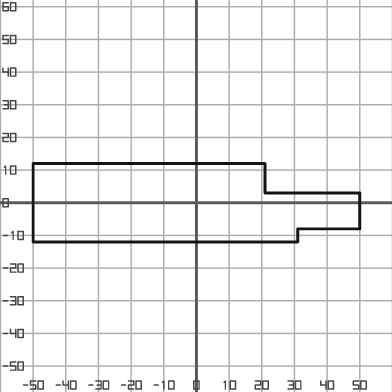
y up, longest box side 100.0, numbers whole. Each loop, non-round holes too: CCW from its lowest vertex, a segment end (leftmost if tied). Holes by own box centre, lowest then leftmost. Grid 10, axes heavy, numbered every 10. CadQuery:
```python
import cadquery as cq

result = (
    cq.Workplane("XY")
    .moveTo(-50.0, -12.0)
    .lineTo(31.0, -12.0)
    .lineTo(31.0, -8.0)
    .lineTo(50.0, -8.0)
    .lineTo(50.0, 3.0)
    .lineTo(21.0, 3.0)
    .lineTo(21.0, 12.0)
    .lineTo(-50.0, 12.0)
    .close()
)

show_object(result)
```